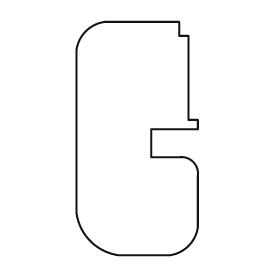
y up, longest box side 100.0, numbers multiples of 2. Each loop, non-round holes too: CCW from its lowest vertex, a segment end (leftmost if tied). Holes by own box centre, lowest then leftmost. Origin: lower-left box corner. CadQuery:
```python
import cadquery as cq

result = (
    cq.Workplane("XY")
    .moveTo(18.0, 0.0)
    .lineTo(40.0, 0.0)
    .threePointArc((48.0, 4.0), (52.0, 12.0))
    .lineTo(52.0, 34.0)
    .threePointArc((50.0, 40.0), (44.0, 42.0))
    .lineTo(32.0, 42.0)
    .lineTo(32.0, 54.0)
    .lineTo(52.0, 54.0)
    .lineTo(52.0, 58.0)
    .lineTo(48.0, 58.0)
    .lineTo(48.0, 94.0)
    .lineTo(44.0, 94.0)
    .lineTo(44.0, 100.0)
    .lineTo(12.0, 100.0)
    .threePointArc((4.0, 96.0), (0.0, 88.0))
    .lineTo(0.0, 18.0)
    .threePointArc((6.0, 6.0), (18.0, 0.0))
    .close()
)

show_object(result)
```